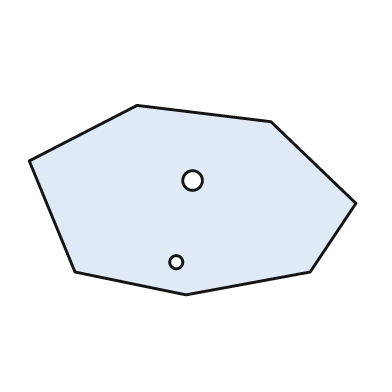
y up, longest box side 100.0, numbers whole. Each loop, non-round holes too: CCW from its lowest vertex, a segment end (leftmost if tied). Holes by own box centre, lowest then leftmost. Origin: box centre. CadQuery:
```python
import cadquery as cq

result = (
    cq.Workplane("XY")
    .moveTo(-2.0, -29.0)
    .lineTo(36.0, -22.0)
    .lineTo(50.0, -1.0)
    .lineTo(24.0, 24.0)
    .lineTo(-17.0, 29.0)
    .lineTo(-50.0, 12.0)
    .lineTo(-36.0, -22.0)
    .close()
    .moveTo(-5.0, -19.0)
    .circle(2.0)
    .moveTo(0.0, 6.0)
    .circle(3.0)
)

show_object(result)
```